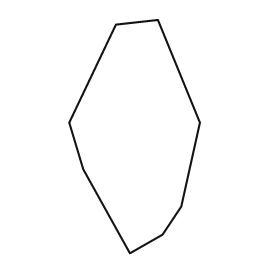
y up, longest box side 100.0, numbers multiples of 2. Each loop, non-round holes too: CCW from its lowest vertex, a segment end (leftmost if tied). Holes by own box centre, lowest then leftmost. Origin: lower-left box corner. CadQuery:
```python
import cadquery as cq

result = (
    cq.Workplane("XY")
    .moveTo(26.0, 0.0)
    .lineTo(40.0, 8.0)
    .lineTo(48.0, 20.0)
    .lineTo(56.0, 56.0)
    .lineTo(38.0, 100.0)
    .lineTo(20.0, 98.0)
    .lineTo(0.0, 56.0)
    .lineTo(6.0, 36.0)
    .close()
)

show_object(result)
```